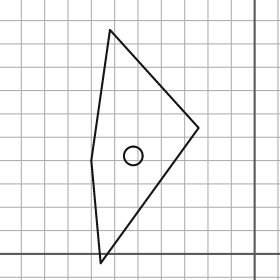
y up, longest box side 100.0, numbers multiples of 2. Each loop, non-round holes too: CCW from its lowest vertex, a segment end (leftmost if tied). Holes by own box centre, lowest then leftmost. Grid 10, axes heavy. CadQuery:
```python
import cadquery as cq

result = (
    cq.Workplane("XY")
    .moveTo(-66.0, -4.0)
    .lineTo(-24.0, 54.0)
    .lineTo(-62.0, 96.0)
    .lineTo(-70.0, 40.0)
    .close()
    .moveTo(-52.0, 42.0)
    .circle(4.0)
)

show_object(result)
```